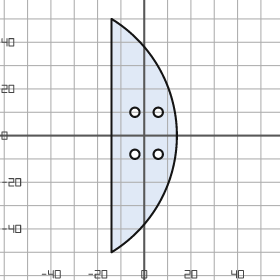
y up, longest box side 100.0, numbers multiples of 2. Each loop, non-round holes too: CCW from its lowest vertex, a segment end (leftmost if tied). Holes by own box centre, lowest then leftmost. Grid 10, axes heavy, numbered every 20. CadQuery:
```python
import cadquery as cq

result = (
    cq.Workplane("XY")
    .moveTo(-14.0, -50.0)
    .threePointArc((14.0, 0.0), (-14.0, 50.0))
    .close()
    .moveTo(-4.0, -8.0)
    .circle(2.0)
    .moveTo(6.0, -8.0)
    .circle(2.0)
    .moveTo(-4.0, 10.0)
    .circle(2.0)
    .moveTo(6.0, 10.0)
    .circle(2.0)
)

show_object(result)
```